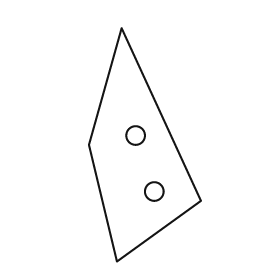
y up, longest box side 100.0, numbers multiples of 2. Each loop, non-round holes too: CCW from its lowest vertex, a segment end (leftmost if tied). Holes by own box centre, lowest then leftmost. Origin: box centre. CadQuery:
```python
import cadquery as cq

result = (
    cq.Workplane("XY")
    .moveTo(-12.0, -50.0)
    .lineTo(24.0, -24.0)
    .lineTo(-10.0, 50.0)
    .lineTo(-24.0, 0.0)
    .close()
    .moveTo(4.0, -20.0)
    .circle(4.0)
    .moveTo(-4.0, 4.0)
    .circle(4.0)
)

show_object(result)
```